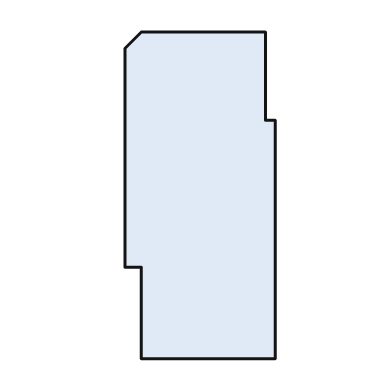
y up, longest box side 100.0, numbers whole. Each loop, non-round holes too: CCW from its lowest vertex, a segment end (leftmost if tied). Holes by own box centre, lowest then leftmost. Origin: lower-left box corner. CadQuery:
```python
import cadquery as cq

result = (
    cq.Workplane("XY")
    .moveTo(5.0, 0.0)
    .lineTo(46.0, 0.0)
    .lineTo(46.0, 73.0)
    .lineTo(43.0, 73.0)
    .lineTo(43.0, 100.0)
    .lineTo(5.0, 100.0)
    .lineTo(0.0, 95.0)
    .lineTo(0.0, 28.0)
    .lineTo(5.0, 28.0)
    .close()
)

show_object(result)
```